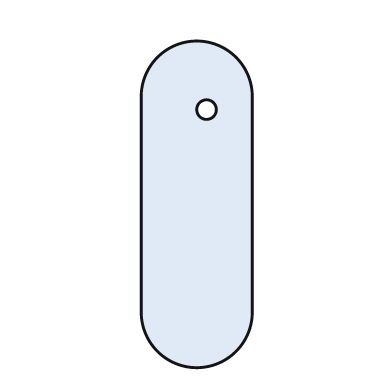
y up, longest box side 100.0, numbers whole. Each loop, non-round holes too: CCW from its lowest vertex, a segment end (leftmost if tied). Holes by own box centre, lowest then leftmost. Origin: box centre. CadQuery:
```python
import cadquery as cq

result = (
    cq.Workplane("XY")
    .moveTo(-17.0, -33.0)
    .threePointArc((0.0, -50.0), (17.0, -33.0))
    .lineTo(17.0, 33.0)
    .threePointArc((0.0, 50.0), (-17.0, 33.0))
    .close()
    .moveTo(3.0, 29.0)
    .circle(3.0)
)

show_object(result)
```